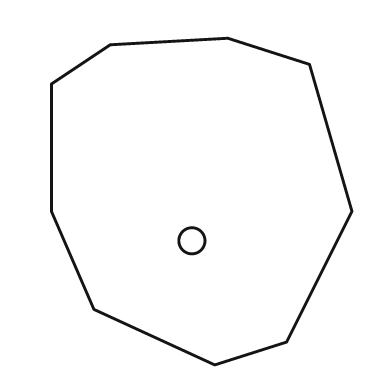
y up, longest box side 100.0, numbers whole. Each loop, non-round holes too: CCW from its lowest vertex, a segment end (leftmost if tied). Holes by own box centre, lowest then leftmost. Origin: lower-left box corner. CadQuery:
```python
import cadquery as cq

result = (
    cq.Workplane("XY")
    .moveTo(50.0, 0.0)
    .lineTo(72.0, 7.0)
    .lineTo(92.0, 47.0)
    .lineTo(79.0, 92.0)
    .lineTo(54.0, 100.0)
    .lineTo(18.0, 98.0)
    .lineTo(0.0, 86.0)
    .lineTo(0.0, 47.0)
    .lineTo(13.0, 17.0)
    .close()
    .moveTo(43.0, 38.0)
    .circle(4.0)
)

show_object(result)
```